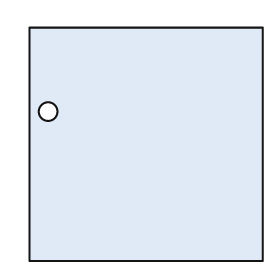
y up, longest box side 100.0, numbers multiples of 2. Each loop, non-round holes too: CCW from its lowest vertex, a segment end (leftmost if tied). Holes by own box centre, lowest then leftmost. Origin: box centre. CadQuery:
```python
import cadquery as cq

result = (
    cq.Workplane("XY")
    .moveTo(-50.0, -50.0)
    .lineTo(50.0, -50.0)
    .lineTo(50.0, 50.0)
    .lineTo(-50.0, 50.0)
    .close()
    .moveTo(-42.0, 14.0)
    .circle(4.0)
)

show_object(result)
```